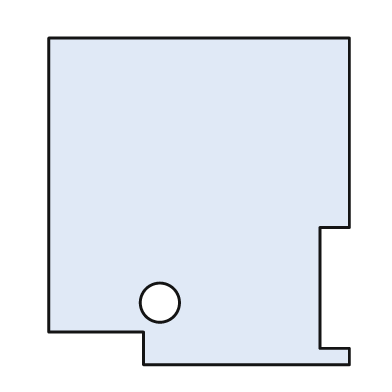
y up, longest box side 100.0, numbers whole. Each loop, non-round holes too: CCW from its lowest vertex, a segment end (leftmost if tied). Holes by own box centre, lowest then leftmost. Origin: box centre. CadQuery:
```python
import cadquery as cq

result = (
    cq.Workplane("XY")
    .moveTo(-17.0, -50.0)
    .lineTo(46.0, -50.0)
    .lineTo(46.0, -45.0)
    .lineTo(37.0, -45.0)
    .lineTo(37.0, -8.0)
    .lineTo(46.0, -8.0)
    .lineTo(46.0, 50.0)
    .lineTo(-46.0, 50.0)
    .lineTo(-46.0, -40.0)
    .lineTo(-17.0, -40.0)
    .close()
    .moveTo(-12.0, -31.0)
    .circle(6.0)
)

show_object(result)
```